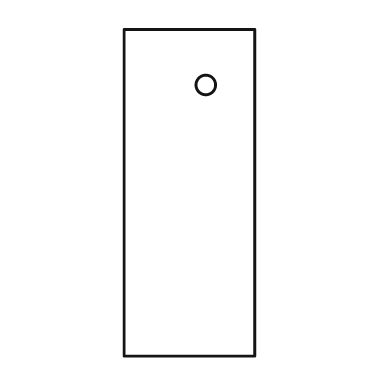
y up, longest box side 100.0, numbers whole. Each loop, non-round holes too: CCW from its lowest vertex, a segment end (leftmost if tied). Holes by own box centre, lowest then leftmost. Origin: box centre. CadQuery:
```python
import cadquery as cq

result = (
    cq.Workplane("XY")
    .moveTo(-20.0, -50.0)
    .lineTo(20.0, -50.0)
    .lineTo(20.0, 50.0)
    .lineTo(-20.0, 50.0)
    .close()
    .moveTo(5.0, 33.0)
    .circle(3.0)
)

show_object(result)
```